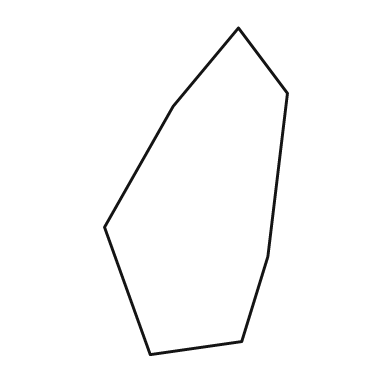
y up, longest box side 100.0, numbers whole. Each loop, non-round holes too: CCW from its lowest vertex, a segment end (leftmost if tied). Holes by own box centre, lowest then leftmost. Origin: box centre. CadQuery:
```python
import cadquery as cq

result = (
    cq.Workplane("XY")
    .moveTo(-14.0, -50.0)
    .lineTo(14.0, -46.0)
    .lineTo(22.0, -20.0)
    .lineTo(28.0, 30.0)
    .lineTo(13.0, 50.0)
    .lineTo(-7.0, 26.0)
    .lineTo(-28.0, -11.0)
    .close()
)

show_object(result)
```